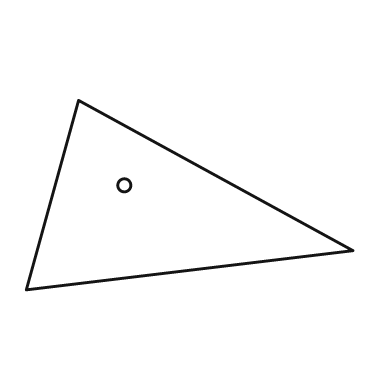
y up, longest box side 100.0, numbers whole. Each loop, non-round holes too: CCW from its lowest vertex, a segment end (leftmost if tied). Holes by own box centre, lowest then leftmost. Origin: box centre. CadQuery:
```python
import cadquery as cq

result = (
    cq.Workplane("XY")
    .moveTo(-50.0, -29.0)
    .lineTo(50.0, -17.0)
    .lineTo(-34.0, 29.0)
    .close()
    .moveTo(-20.0, 3.0)
    .circle(2.0)
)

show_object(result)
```